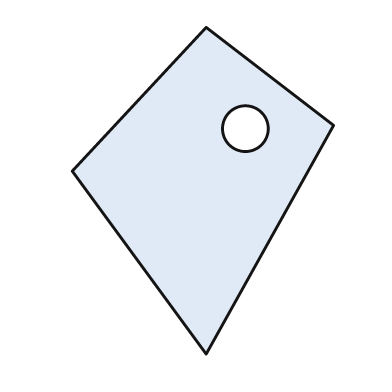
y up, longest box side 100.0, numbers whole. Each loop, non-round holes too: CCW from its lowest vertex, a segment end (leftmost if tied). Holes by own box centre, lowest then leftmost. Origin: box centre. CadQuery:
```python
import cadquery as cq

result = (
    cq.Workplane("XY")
    .moveTo(1.0, -50.0)
    .lineTo(40.0, 20.0)
    .lineTo(1.0, 50.0)
    .lineTo(-40.0, 6.0)
    .close()
    .moveTo(13.0, 19.0)
    .circle(7.0)
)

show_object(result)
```